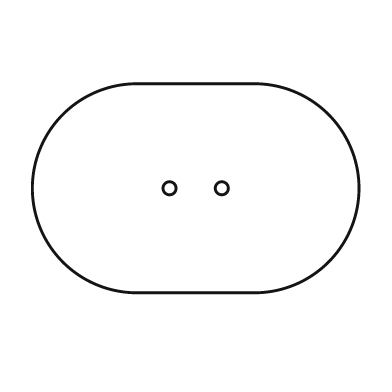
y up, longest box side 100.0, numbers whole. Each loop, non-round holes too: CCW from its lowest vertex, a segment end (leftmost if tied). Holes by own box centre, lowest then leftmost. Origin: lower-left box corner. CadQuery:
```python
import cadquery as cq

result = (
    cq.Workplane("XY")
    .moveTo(32.0, 0.0)
    .lineTo(68.0, 0.0)
    .threePointArc((100.0, 32.0), (68.0, 64.0))
    .lineTo(32.0, 64.0)
    .threePointArc((0.0, 32.0), (32.0, 0.0))
    .close()
    .moveTo(42.0, 32.0)
    .circle(2.0)
    .moveTo(58.0, 32.0)
    .circle(2.0)
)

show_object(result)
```